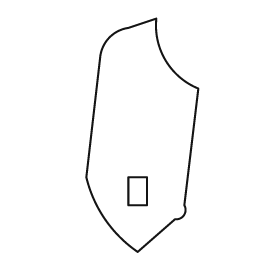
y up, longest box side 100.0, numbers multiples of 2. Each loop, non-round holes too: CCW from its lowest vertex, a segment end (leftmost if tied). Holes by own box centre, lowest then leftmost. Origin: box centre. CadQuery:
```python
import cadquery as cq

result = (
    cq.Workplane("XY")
    .moveTo(-2.0, -50.0)
    .lineTo(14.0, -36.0)
    .threePointArc((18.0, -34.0), (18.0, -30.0))
    .lineTo(24.0, 20.0)
    .threePointArc((10.0, 32.0), (6.0, 50.0))
    .lineTo(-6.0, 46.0)
    .threePointArc((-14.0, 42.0), (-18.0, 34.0))
    .lineTo(-24.0, -18.0)
    .threePointArc((-16.0, -36.0), (-2.0, -50.0))
    .close()
    .moveTo(-6.0, -30.0)
    .lineTo(2.0, -30.0)
    .lineTo(2.0, -18.0)
    .lineTo(-6.0, -18.0)
    .close()
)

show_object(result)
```